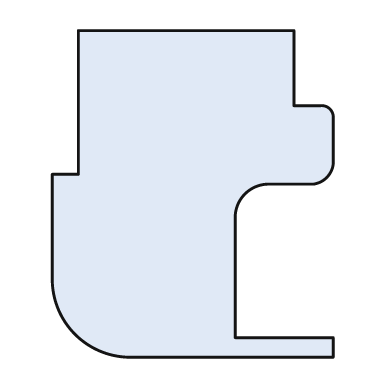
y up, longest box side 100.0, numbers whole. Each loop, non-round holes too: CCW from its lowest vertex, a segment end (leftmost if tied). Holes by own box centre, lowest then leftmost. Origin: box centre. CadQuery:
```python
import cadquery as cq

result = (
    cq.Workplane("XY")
    .moveTo(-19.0, -50.0)
    .lineTo(43.0, -50.0)
    .lineTo(43.0, -44.0)
    .lineTo(13.0, -44.0)
    .lineTo(13.0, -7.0)
    .threePointArc((16.0, 0.0), (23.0, 3.0))
    .lineTo(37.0, 3.0)
    .threePointArc((41.0, 5.0), (43.0, 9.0))
    .lineTo(43.0, 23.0)
    .threePointArc((42.0, 26.0), (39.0, 27.0))
    .lineTo(31.0, 27.0)
    .lineTo(31.0, 50.0)
    .lineTo(-35.0, 50.0)
    .lineTo(-35.0, 6.0)
    .lineTo(-43.0, 6.0)
    .lineTo(-43.0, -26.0)
    .threePointArc((-36.0, -43.0), (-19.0, -50.0))
    .close()
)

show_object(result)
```